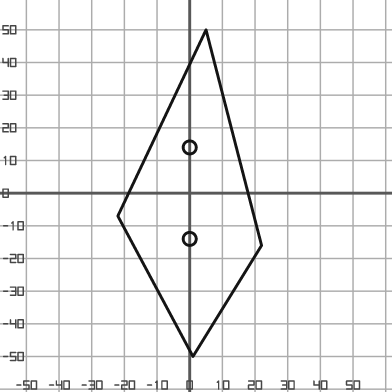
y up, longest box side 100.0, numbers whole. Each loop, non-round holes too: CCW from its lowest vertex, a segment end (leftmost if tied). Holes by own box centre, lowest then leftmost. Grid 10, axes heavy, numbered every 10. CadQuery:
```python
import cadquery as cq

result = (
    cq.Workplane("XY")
    .moveTo(1.0, -50.0)
    .lineTo(22.0, -16.0)
    .lineTo(5.0, 50.0)
    .lineTo(-22.0, -7.0)
    .close()
    .moveTo(0.0, -14.0)
    .circle(2.0)
    .moveTo(0.0, 14.0)
    .circle(2.0)
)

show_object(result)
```